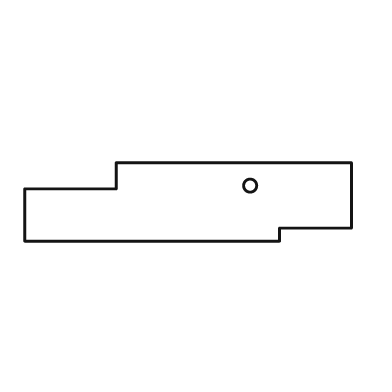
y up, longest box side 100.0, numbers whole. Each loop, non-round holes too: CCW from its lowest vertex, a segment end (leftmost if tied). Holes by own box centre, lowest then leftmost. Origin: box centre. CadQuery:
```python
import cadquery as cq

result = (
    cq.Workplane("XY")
    .moveTo(-50.0, -12.0)
    .lineTo(28.0, -12.0)
    .lineTo(28.0, -8.0)
    .lineTo(50.0, -8.0)
    .lineTo(50.0, 12.0)
    .lineTo(-22.0, 12.0)
    .lineTo(-22.0, 4.0)
    .lineTo(-50.0, 4.0)
    .close()
    .moveTo(19.0, 5.0)
    .circle(2.0)
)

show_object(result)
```